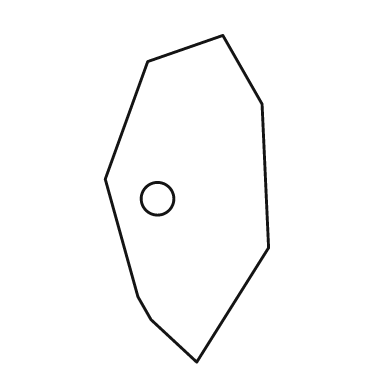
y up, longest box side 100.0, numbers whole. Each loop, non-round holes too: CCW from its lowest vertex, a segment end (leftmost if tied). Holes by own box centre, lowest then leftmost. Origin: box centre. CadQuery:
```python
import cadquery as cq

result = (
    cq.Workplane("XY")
    .moveTo(3.0, -50.0)
    .lineTo(25.0, -15.0)
    .lineTo(23.0, 29.0)
    .lineTo(11.0, 50.0)
    .lineTo(-12.0, 42.0)
    .lineTo(-25.0, 6.0)
    .lineTo(-15.0, -30.0)
    .lineTo(-11.0, -37.0)
    .close()
    .moveTo(-9.0, 0.0)
    .circle(5.0)
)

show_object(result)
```